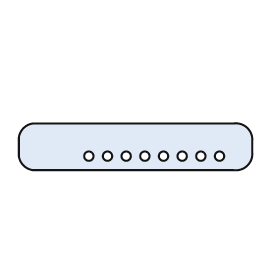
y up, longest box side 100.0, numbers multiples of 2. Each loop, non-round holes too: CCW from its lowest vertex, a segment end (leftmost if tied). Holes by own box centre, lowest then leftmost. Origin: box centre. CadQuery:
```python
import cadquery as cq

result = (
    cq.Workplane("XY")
    .moveTo(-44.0, -10.0)
    .lineTo(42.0, -10.0)
    .threePointArc((48.0, -8.0), (50.0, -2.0))
    .lineTo(50.0, 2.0)
    .threePointArc((48.0, 8.0), (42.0, 10.0))
    .lineTo(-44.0, 10.0)
    .threePointArc((-48.0, 8.0), (-50.0, 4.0))
    .lineTo(-50.0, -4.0)
    .threePointArc((-48.0, -8.0), (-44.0, -10.0))
    .close()
    .moveTo(-20.0, -4.0)
    .circle(2.0)
    .moveTo(-12.0, -4.0)
    .circle(2.0)
    .moveTo(-4.0, -4.0)
    .circle(2.0)
    .moveTo(4.0, -4.0)
    .circle(2.0)
    .moveTo(12.0, -4.0)
    .circle(2.0)
    .moveTo(20.0, -4.0)
    .circle(2.0)
    .moveTo(28.0, -4.0)
    .circle(2.0)
    .moveTo(36.0, -4.0)
    .circle(2.0)
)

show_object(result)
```